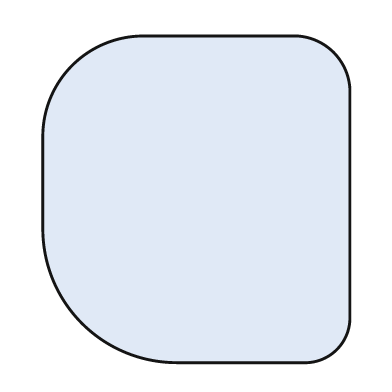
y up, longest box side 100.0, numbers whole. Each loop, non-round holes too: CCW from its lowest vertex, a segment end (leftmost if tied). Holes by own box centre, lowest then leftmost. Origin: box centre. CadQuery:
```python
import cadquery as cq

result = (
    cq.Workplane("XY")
    .moveTo(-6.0, -50.0)
    .lineTo(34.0, -50.0)
    .threePointArc((43.0, -46.0), (47.0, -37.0))
    .lineTo(47.0, 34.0)
    .threePointArc((42.0, 45.0), (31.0, 50.0))
    .lineTo(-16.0, 50.0)
    .threePointArc((-38.0, 41.0), (-47.0, 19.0))
    .lineTo(-47.0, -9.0)
    .threePointArc((-35.0, -38.0), (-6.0, -50.0))
    .close()
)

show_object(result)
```